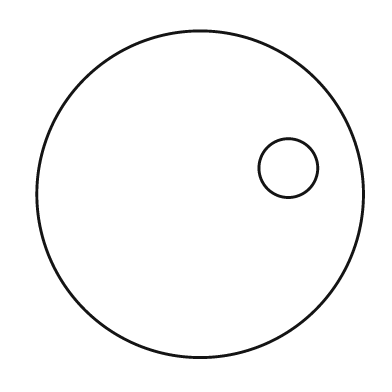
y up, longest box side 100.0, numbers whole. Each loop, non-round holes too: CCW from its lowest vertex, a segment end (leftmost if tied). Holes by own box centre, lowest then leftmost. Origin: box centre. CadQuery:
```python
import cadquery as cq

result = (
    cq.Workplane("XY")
    .moveTo(0.0, 0.0)
    .circle(50.0)
    .moveTo(27.0, 8.0)
    .circle(9.0)
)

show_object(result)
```